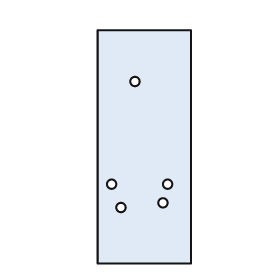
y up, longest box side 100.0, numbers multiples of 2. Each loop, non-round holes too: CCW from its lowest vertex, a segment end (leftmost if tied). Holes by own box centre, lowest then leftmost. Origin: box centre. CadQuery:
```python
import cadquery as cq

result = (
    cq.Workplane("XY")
    .moveTo(-20.0, -50.0)
    .lineTo(20.0, -50.0)
    .lineTo(20.0, 50.0)
    .lineTo(-20.0, 50.0)
    .close()
    .moveTo(-10.0, -26.0)
    .circle(2.0)
    .moveTo(8.0, -24.0)
    .circle(2.0)
    .moveTo(-14.0, -16.0)
    .circle(2.0)
    .moveTo(10.0, -16.0)
    .circle(2.0)
    .moveTo(-4.0, 28.0)
    .circle(2.0)
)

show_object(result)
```